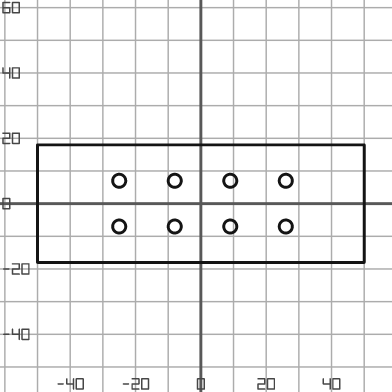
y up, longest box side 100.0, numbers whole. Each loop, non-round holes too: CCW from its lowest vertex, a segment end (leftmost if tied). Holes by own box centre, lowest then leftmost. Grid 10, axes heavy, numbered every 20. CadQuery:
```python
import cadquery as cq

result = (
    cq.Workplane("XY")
    .moveTo(-50.0, -18.0)
    .lineTo(50.0, -18.0)
    .lineTo(50.0, 18.0)
    .lineTo(-50.0, 18.0)
    .close()
    .moveTo(-25.0, -7.0)
    .circle(2.0)
    .moveTo(-8.0, -7.0)
    .circle(2.0)
    .moveTo(9.0, -7.0)
    .circle(2.0)
    .moveTo(26.0, -7.0)
    .circle(2.0)
    .moveTo(-25.0, 7.0)
    .circle(2.0)
    .moveTo(-8.0, 7.0)
    .circle(2.0)
    .moveTo(9.0, 7.0)
    .circle(2.0)
    .moveTo(26.0, 7.0)
    .circle(2.0)
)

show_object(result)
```